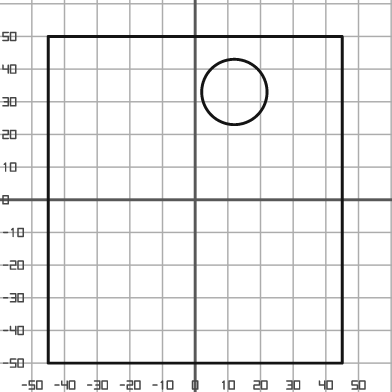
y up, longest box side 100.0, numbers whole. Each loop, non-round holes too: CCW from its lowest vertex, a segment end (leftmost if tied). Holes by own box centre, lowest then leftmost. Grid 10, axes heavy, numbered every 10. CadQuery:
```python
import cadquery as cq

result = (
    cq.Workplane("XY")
    .moveTo(-45.0, -50.0)
    .lineTo(45.0, -50.0)
    .lineTo(45.0, 50.0)
    .lineTo(-45.0, 50.0)
    .close()
    .moveTo(12.0, 33.0)
    .circle(10.0)
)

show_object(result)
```